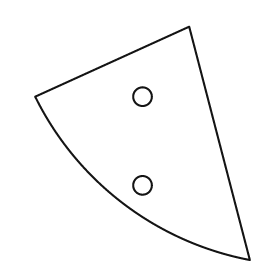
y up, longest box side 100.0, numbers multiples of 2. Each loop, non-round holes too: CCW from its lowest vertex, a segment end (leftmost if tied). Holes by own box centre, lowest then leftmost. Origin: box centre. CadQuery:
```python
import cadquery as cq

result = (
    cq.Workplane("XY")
    .moveTo(46.0, -50.0)
    .lineTo(20.0, 50.0)
    .lineTo(-46.0, 20.0)
    .threePointArc((-8.0, -26.0), (46.0, -50.0))
    .close()
    .moveTo(0.0, -18.0)
    .circle(4.0)
    .moveTo(0.0, 20.0)
    .circle(4.0)
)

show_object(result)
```